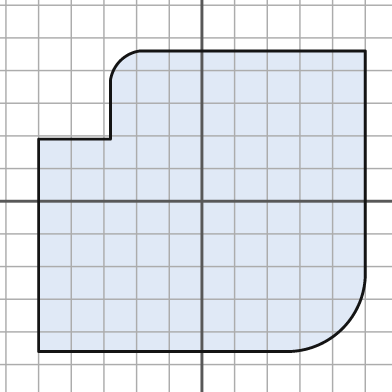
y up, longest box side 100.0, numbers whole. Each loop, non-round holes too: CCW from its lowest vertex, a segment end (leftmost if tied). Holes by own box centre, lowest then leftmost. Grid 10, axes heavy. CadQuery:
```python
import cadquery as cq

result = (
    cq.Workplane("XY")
    .moveTo(-50.0, -46.0)
    .lineTo(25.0, -46.0)
    .threePointArc((43.0, -39.0), (50.0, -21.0))
    .lineTo(50.0, 46.0)
    .lineTo(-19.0, 46.0)
    .threePointArc((-25.0, 43.0), (-28.0, 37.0))
    .lineTo(-28.0, 19.0)
    .lineTo(-50.0, 19.0)
    .close()
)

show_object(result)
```